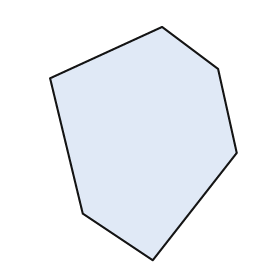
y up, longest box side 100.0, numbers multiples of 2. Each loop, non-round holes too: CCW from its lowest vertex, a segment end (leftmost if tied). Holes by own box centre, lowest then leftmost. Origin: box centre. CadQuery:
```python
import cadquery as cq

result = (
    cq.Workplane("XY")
    .moveTo(4.0, -50.0)
    .lineTo(40.0, -4.0)
    .lineTo(32.0, 32.0)
    .lineTo(8.0, 50.0)
    .lineTo(-40.0, 28.0)
    .lineTo(-26.0, -30.0)
    .close()
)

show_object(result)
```